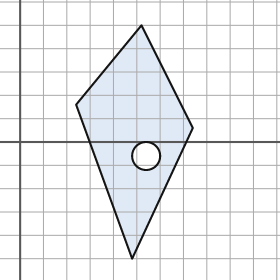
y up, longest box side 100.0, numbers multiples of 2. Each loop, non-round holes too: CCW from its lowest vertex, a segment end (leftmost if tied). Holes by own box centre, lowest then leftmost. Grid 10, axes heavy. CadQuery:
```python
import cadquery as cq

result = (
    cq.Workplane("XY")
    .moveTo(48.0, -50.0)
    .lineTo(74.0, 6.0)
    .lineTo(52.0, 50.0)
    .lineTo(24.0, 16.0)
    .close()
    .moveTo(54.0, -6.0)
    .circle(6.0)
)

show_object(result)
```